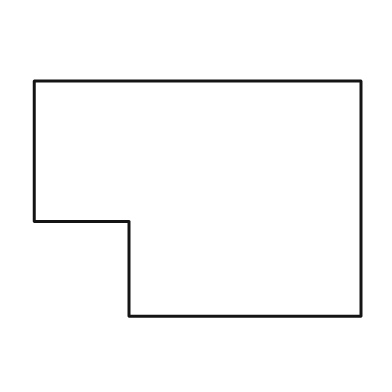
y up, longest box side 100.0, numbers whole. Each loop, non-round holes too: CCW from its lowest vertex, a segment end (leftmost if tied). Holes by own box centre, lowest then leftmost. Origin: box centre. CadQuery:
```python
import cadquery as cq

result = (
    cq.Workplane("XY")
    .moveTo(-21.0, -36.0)
    .lineTo(50.0, -36.0)
    .lineTo(50.0, 36.0)
    .lineTo(-50.0, 36.0)
    .lineTo(-50.0, -7.0)
    .lineTo(-21.0, -7.0)
    .close()
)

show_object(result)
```